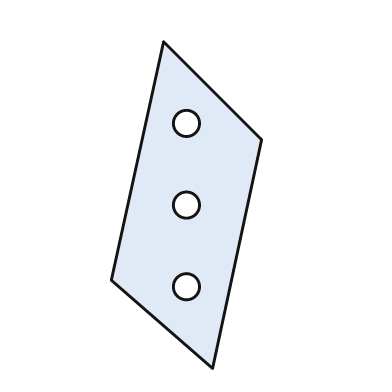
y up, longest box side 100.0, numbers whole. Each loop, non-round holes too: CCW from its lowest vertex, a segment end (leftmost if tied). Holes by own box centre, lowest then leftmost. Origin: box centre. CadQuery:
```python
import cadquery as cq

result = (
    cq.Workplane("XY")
    .moveTo(8.0, -50.0)
    .lineTo(23.0, 20.0)
    .lineTo(-7.0, 50.0)
    .lineTo(-23.0, -23.0)
    .close()
    .moveTo(0.0, -25.0)
    .circle(4.0)
    .moveTo(0.0, 0.0)
    .circle(4.0)
    .moveTo(0.0, 25.0)
    .circle(4.0)
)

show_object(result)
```